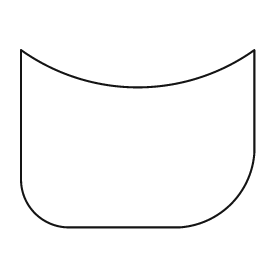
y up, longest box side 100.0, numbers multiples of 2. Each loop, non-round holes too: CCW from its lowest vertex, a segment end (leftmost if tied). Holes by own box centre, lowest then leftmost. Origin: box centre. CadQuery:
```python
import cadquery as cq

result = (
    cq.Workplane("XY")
    .moveTo(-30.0, -38.0)
    .lineTo(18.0, -38.0)
    .threePointArc((40.0, -28.0), (50.0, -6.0))
    .lineTo(50.0, 38.0)
    .threePointArc((0.0, 22.0), (-50.0, 38.0))
    .lineTo(-50.0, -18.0)
    .threePointArc((-44.0, -32.0), (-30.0, -38.0))
    .close()
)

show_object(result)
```